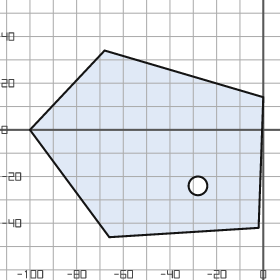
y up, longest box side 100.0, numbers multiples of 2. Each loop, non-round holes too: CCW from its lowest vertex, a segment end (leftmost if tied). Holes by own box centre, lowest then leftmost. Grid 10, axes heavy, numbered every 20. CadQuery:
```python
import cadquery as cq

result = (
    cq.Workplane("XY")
    .moveTo(-66.0, -46.0)
    .lineTo(-2.0, -42.0)
    .lineTo(0.0, 14.0)
    .lineTo(-68.0, 34.0)
    .lineTo(-100.0, 0.0)
    .close()
    .moveTo(-28.0, -24.0)
    .circle(4.0)
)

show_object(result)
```